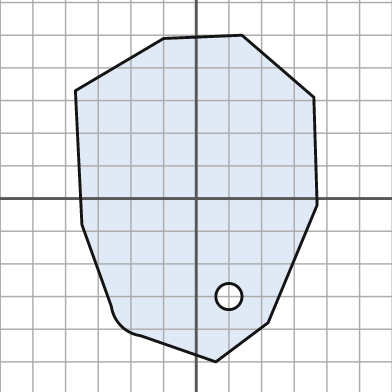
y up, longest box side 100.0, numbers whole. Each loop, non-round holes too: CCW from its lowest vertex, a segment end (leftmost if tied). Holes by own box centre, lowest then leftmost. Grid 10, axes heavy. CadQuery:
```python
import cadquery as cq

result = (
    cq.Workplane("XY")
    .moveTo(6.0, -50.0)
    .lineTo(22.0, -38.0)
    .lineTo(37.0, -2.0)
    .lineTo(36.0, 31.0)
    .lineTo(14.0, 50.0)
    .lineTo(-10.0, 49.0)
    .lineTo(-37.0, 33.0)
    .lineTo(-35.0, -8.0)
    .lineTo(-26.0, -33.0)
    .threePointArc((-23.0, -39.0), (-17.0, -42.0))
    .close()
    .moveTo(10.0, -30.0)
    .circle(4.0)
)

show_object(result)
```